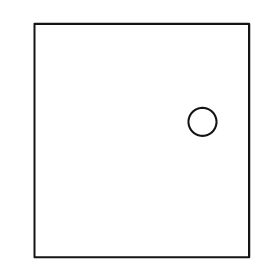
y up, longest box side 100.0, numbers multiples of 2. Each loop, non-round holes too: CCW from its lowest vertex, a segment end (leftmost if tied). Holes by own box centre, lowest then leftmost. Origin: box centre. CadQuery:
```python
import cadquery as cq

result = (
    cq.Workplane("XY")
    .moveTo(-46.0, -50.0)
    .lineTo(46.0, -50.0)
    .lineTo(46.0, 50.0)
    .lineTo(-46.0, 50.0)
    .close()
    .moveTo(26.0, 8.0)
    .circle(6.0)
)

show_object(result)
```